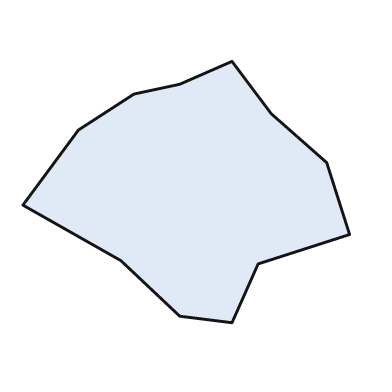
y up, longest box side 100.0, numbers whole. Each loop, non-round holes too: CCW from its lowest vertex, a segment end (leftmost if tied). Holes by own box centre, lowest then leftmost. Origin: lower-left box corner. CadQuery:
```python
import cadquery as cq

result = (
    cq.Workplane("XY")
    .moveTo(64.0, 0.0)
    .lineTo(72.0, 18.0)
    .lineTo(100.0, 27.0)
    .lineTo(93.0, 49.0)
    .lineTo(76.0, 64.0)
    .lineTo(64.0, 80.0)
    .lineTo(48.0, 73.0)
    .lineTo(34.0, 70.0)
    .lineTo(17.0, 59.0)
    .lineTo(0.0, 36.0)
    .lineTo(30.0, 19.0)
    .lineTo(48.0, 2.0)
    .close()
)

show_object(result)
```